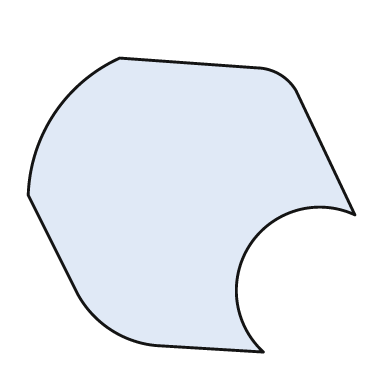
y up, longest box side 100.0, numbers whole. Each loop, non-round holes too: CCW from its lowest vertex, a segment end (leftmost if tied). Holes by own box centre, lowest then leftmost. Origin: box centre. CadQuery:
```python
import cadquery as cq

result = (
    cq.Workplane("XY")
    .moveTo(22.0, -45.0)
    .threePointArc((18.0, -12.0), (50.0, -3.0))
    .lineTo(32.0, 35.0)
    .threePointArc((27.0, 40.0), (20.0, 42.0))
    .lineTo(-22.0, 45.0)
    .threePointArc((-42.0, 28.0), (-50.0, 3.0))
    .lineTo(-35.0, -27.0)
    .threePointArc((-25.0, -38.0), (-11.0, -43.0))
    .close()
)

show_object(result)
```